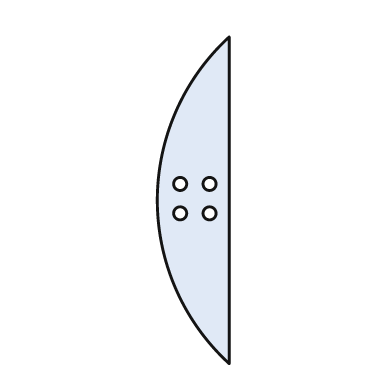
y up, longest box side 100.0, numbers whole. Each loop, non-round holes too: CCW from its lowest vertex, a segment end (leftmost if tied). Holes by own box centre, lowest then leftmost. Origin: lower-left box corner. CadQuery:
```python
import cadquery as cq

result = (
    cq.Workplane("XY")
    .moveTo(22.0, 0.0)
    .lineTo(22.0, 100.0)
    .threePointArc((0.0, 50.0), (22.0, 0.0))
    .close()
    .moveTo(7.0, 46.0)
    .circle(2.0)
    .moveTo(16.0, 46.0)
    .circle(2.0)
    .moveTo(7.0, 55.0)
    .circle(2.0)
    .moveTo(16.0, 55.0)
    .circle(2.0)
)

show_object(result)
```